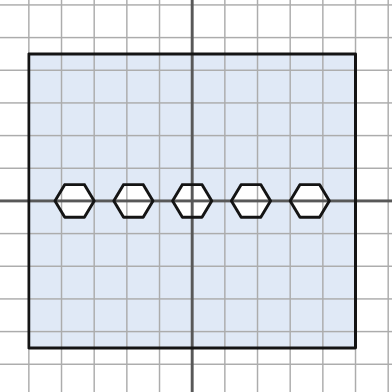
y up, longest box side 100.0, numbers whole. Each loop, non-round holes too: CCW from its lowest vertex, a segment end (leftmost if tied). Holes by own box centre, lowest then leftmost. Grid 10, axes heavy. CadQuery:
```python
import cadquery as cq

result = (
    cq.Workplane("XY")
    .moveTo(-50.0, -45.0)
    .lineTo(50.0, -45.0)
    .lineTo(50.0, 45.0)
    .lineTo(-50.0, 45.0)
    .close()
    .moveTo(-39.0, -5.0)
    .lineTo(-33.0, -5.0)
    .lineTo(-30.0, 0.0)
    .lineTo(-33.0, 5.0)
    .lineTo(-39.0, 5.0)
    .lineTo(-42.0, 0.0)
    .close()
    .moveTo(-21.0, -5.0)
    .lineTo(-15.0, -5.0)
    .lineTo(-12.0, 0.0)
    .lineTo(-15.0, 5.0)
    .lineTo(-21.0, 5.0)
    .lineTo(-24.0, 0.0)
    .close()
    .moveTo(-3.0, -5.0)
    .lineTo(3.0, -5.0)
    .lineTo(6.0, 0.0)
    .lineTo(3.0, 5.0)
    .lineTo(-3.0, 5.0)
    .lineTo(-6.0, 0.0)
    .close()
    .moveTo(15.0, -5.0)
    .lineTo(21.0, -5.0)
    .lineTo(24.0, 0.0)
    .lineTo(21.0, 5.0)
    .lineTo(15.0, 5.0)
    .lineTo(12.0, 0.0)
    .close()
    .moveTo(33.0, -5.0)
    .lineTo(39.0, -5.0)
    .lineTo(42.0, 0.0)
    .lineTo(39.0, 5.0)
    .lineTo(33.0, 5.0)
    .lineTo(30.0, 0.0)
    .close()
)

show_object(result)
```